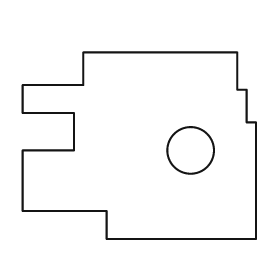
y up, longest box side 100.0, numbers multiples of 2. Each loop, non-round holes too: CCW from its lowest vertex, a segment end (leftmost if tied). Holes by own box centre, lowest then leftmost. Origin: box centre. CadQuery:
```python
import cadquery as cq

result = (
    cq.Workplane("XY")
    .moveTo(-14.0, -40.0)
    .lineTo(50.0, -40.0)
    .lineTo(50.0, 10.0)
    .lineTo(46.0, 10.0)
    .lineTo(46.0, 24.0)
    .lineTo(42.0, 24.0)
    .lineTo(42.0, 40.0)
    .lineTo(-24.0, 40.0)
    .lineTo(-24.0, 26.0)
    .lineTo(-50.0, 26.0)
    .lineTo(-50.0, 14.0)
    .lineTo(-28.0, 14.0)
    .lineTo(-28.0, -2.0)
    .lineTo(-50.0, -2.0)
    .lineTo(-50.0, -28.0)
    .lineTo(-14.0, -28.0)
    .close()
    .moveTo(22.0, -2.0)
    .circle(10.0)
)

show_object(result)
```